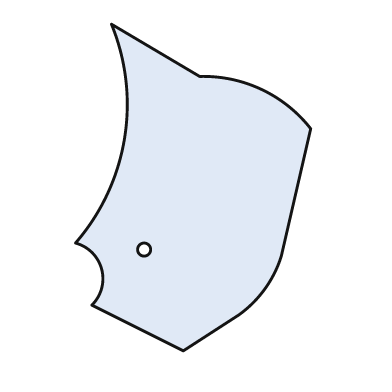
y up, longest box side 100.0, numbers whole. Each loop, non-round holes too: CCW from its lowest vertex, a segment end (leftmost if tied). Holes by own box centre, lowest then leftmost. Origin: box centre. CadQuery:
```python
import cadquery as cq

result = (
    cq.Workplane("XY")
    .moveTo(-3.0, -50.0)
    .lineTo(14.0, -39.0)
    .threePointArc((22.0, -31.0), (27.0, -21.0))
    .lineTo(36.0, 18.0)
    .threePointArc((21.0, 30.0), (2.0, 34.0))
    .lineTo(-25.0, 50.0)
    .threePointArc((-21.0, 15.0), (-36.0, -17.0))
    .threePointArc((-28.0, -25.0), (-31.0, -36.0))
    .close()
    .moveTo(-15.0, -19.0)
    .circle(2.0)
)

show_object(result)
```